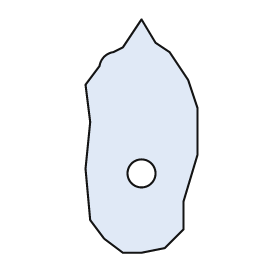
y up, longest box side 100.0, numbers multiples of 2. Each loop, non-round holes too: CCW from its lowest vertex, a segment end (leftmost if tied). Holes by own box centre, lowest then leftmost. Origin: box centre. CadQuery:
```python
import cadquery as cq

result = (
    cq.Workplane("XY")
    .moveTo(-8.0, -50.0)
    .lineTo(0.0, -50.0)
    .lineTo(10.0, -48.0)
    .lineTo(18.0, -40.0)
    .lineTo(18.0, -28.0)
    .lineTo(24.0, -8.0)
    .lineTo(24.0, 12.0)
    .lineTo(20.0, 24.0)
    .lineTo(12.0, 36.0)
    .lineTo(6.0, 40.0)
    .lineTo(0.0, 50.0)
    .lineTo(-8.0, 38.0)
    .lineTo(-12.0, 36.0)
    .threePointArc((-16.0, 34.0), (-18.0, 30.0))
    .lineTo(-24.0, 22.0)
    .lineTo(-22.0, 6.0)
    .lineTo(-24.0, -14.0)
    .lineTo(-22.0, -36.0)
    .lineTo(-16.0, -44.0)
    .close()
    .moveTo(0.0, -16.0)
    .circle(6.0)
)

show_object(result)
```